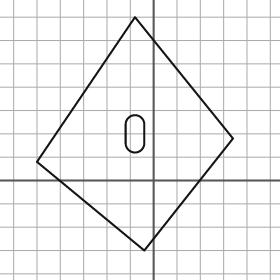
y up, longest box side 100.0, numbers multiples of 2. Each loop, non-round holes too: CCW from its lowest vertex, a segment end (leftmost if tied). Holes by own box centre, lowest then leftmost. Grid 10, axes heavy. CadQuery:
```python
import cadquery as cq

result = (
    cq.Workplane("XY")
    .moveTo(-4.0, -30.0)
    .lineTo(34.0, 18.0)
    .lineTo(-8.0, 70.0)
    .lineTo(-50.0, 8.0)
    .close()
    .moveTo(-12.0, 16.0)
    .threePointArc((-8.0, 12.0), (-4.0, 16.0))
    .lineTo(-4.0, 24.0)
    .threePointArc((-8.0, 28.0), (-12.0, 24.0))
    .close()
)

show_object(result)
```